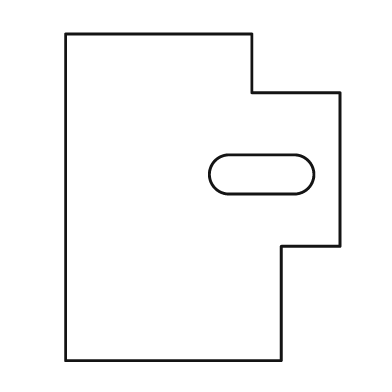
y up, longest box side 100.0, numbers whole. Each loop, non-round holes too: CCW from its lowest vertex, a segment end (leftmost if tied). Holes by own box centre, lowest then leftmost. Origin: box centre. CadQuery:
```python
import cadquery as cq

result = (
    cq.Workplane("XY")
    .moveTo(-42.0, -50.0)
    .lineTo(24.0, -50.0)
    .lineTo(24.0, -15.0)
    .lineTo(42.0, -15.0)
    .lineTo(42.0, 32.0)
    .lineTo(15.0, 32.0)
    .lineTo(15.0, 50.0)
    .lineTo(-42.0, 50.0)
    .close()
    .moveTo(8.0, 1.0)
    .lineTo(28.0, 1.0)
    .threePointArc((34.0, 7.0), (28.0, 13.0))
    .lineTo(8.0, 13.0)
    .threePointArc((2.0, 7.0), (8.0, 1.0))
    .close()
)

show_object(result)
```